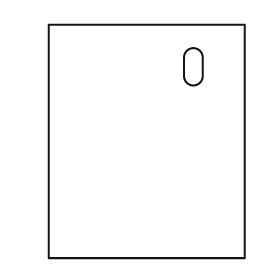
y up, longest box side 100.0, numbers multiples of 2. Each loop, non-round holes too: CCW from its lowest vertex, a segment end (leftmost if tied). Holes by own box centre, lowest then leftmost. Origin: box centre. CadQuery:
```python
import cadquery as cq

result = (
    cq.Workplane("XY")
    .moveTo(-42.0, -50.0)
    .lineTo(42.0, -50.0)
    .lineTo(42.0, 50.0)
    .lineTo(-42.0, 50.0)
    .close()
    .moveTo(16.0, 28.0)
    .threePointArc((20.0, 24.0), (24.0, 28.0))
    .lineTo(24.0, 36.0)
    .threePointArc((20.0, 40.0), (16.0, 36.0))
    .close()
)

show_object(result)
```